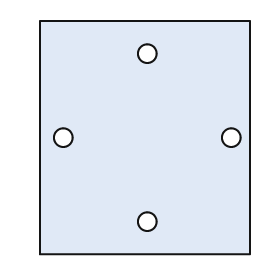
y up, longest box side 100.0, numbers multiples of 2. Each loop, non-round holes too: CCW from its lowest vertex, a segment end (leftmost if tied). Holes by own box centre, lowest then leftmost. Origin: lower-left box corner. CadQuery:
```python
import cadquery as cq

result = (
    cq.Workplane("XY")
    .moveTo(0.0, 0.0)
    .lineTo(90.0, 0.0)
    .lineTo(90.0, 100.0)
    .lineTo(0.0, 100.0)
    .close()
    .moveTo(46.0, 14.0)
    .circle(4.0)
    .moveTo(10.0, 50.0)
    .circle(4.0)
    .moveTo(82.0, 50.0)
    .circle(4.0)
    .moveTo(46.0, 86.0)
    .circle(4.0)
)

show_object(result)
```